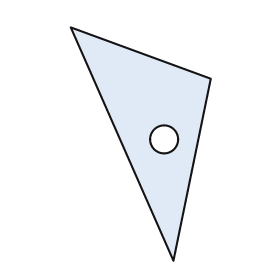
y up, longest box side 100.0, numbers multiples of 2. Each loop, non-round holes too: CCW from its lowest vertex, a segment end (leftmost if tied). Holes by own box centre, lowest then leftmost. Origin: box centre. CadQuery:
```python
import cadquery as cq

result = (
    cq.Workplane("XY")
    .moveTo(14.0, -50.0)
    .lineTo(30.0, 28.0)
    .lineTo(-30.0, 50.0)
    .close()
    .moveTo(10.0, 2.0)
    .circle(6.0)
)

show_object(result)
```